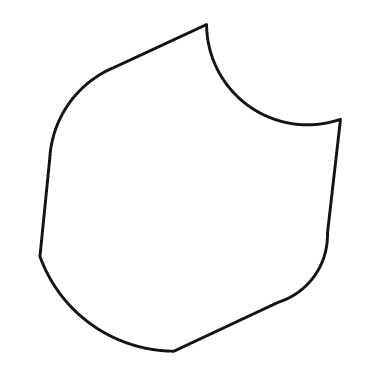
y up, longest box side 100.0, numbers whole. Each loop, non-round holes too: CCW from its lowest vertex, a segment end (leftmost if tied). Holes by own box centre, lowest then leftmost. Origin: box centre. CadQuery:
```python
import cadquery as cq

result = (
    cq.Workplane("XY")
    .moveTo(-5.0, -50.0)
    .lineTo(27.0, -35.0)
    .threePointArc((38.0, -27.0), (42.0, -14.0))
    .lineTo(46.0, 21.0)
    .threePointArc((18.0, 25.0), (5.0, 50.0))
    .lineTo(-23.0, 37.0)
    .threePointArc((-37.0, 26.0), (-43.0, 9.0))
    .lineTo(-46.0, -21.0)
    .threePointArc((-30.0, -42.0), (-5.0, -50.0))
    .close()
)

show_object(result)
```